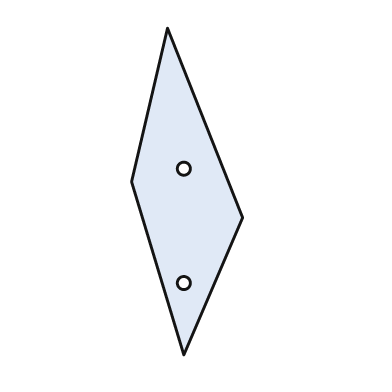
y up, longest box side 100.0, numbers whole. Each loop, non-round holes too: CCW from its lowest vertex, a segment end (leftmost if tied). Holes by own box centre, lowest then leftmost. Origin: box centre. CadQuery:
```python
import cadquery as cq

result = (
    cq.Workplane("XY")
    .moveTo(-1.0, -50.0)
    .lineTo(17.0, -8.0)
    .lineTo(-6.0, 50.0)
    .lineTo(-17.0, 3.0)
    .close()
    .moveTo(-1.0, -28.0)
    .circle(2.0)
    .moveTo(-1.0, 7.0)
    .circle(2.0)
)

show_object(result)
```